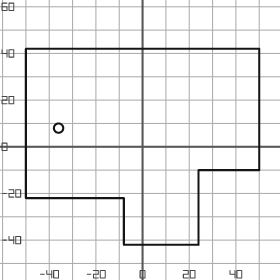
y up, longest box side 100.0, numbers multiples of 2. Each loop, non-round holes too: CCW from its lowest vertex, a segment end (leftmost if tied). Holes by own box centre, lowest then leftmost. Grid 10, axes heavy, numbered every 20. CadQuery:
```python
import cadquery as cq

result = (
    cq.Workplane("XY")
    .moveTo(-8.0, -42.0)
    .lineTo(24.0, -42.0)
    .lineTo(24.0, -10.0)
    .lineTo(50.0, -10.0)
    .lineTo(50.0, 42.0)
    .lineTo(-50.0, 42.0)
    .lineTo(-50.0, -22.0)
    .lineTo(-8.0, -22.0)
    .close()
    .moveTo(-36.0, 8.0)
    .circle(2.0)
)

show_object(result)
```